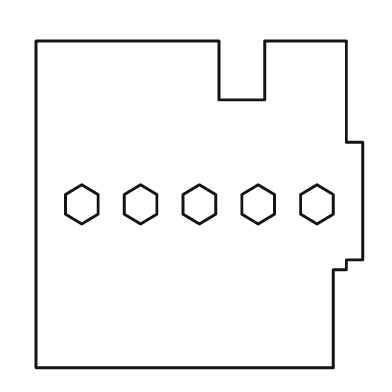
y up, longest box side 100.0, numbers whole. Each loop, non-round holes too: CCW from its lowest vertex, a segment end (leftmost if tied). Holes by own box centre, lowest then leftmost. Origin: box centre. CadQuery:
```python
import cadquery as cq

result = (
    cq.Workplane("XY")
    .moveTo(-50.0, -50.0)
    .lineTo(41.0, -50.0)
    .lineTo(41.0, -20.0)
    .lineTo(45.0, -20.0)
    .lineTo(45.0, -17.0)
    .lineTo(50.0, -17.0)
    .lineTo(50.0, 19.0)
    .lineTo(45.0, 19.0)
    .lineTo(45.0, 50.0)
    .lineTo(20.0, 50.0)
    .lineTo(20.0, 32.0)
    .lineTo(6.0, 32.0)
    .lineTo(6.0, 50.0)
    .lineTo(-50.0, 50.0)
    .close()
    .moveTo(-36.0, -6.0)
    .lineTo(-31.0, -3.0)
    .lineTo(-31.0, 3.0)
    .lineTo(-36.0, 6.0)
    .lineTo(-41.0, 3.0)
    .lineTo(-41.0, -3.0)
    .close()
    .moveTo(-18.0, -6.0)
    .lineTo(-13.0, -3.0)
    .lineTo(-13.0, 3.0)
    .lineTo(-18.0, 6.0)
    .lineTo(-23.0, 3.0)
    .lineTo(-23.0, -3.0)
    .close()
    .moveTo(0.0, -6.0)
    .lineTo(5.0, -3.0)
    .lineTo(5.0, 3.0)
    .lineTo(0.0, 6.0)
    .lineTo(-5.0, 3.0)
    .lineTo(-5.0, -3.0)
    .close()
    .moveTo(18.0, -6.0)
    .lineTo(23.0, -3.0)
    .lineTo(23.0, 3.0)
    .lineTo(18.0, 6.0)
    .lineTo(13.0, 3.0)
    .lineTo(13.0, -3.0)
    .close()
    .moveTo(36.0, -6.0)
    .lineTo(41.0, -3.0)
    .lineTo(41.0, 3.0)
    .lineTo(36.0, 6.0)
    .lineTo(31.0, 3.0)
    .lineTo(31.0, -3.0)
    .close()
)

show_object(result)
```